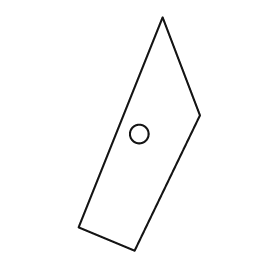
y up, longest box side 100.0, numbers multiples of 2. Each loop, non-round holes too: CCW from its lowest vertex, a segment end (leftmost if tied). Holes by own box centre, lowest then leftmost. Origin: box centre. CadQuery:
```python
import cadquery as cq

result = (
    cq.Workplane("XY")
    .moveTo(-2.0, -50.0)
    .lineTo(26.0, 8.0)
    .lineTo(10.0, 50.0)
    .lineTo(-26.0, -40.0)
    .close()
    .moveTo(0.0, 0.0)
    .circle(4.0)
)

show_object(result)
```